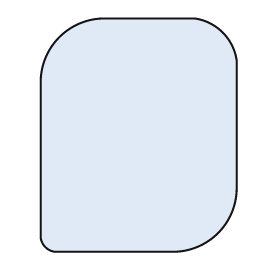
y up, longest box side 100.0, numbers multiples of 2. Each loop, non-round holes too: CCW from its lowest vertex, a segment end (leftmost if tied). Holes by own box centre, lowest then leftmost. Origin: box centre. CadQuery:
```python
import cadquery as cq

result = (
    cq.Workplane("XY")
    .moveTo(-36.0, -50.0)
    .lineTo(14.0, -50.0)
    .threePointArc((34.0, -42.0), (42.0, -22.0))
    .lineTo(42.0, 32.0)
    .threePointArc((36.0, 44.0), (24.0, 50.0))
    .lineTo(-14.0, 50.0)
    .threePointArc((-34.0, 42.0), (-42.0, 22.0))
    .lineTo(-42.0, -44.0)
    .threePointArc((-40.0, -48.0), (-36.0, -50.0))
    .close()
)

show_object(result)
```